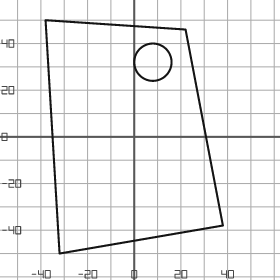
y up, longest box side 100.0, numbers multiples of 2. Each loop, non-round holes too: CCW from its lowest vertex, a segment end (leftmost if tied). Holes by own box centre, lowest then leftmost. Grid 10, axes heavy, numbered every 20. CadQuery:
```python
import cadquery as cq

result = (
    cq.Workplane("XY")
    .moveTo(-32.0, -50.0)
    .lineTo(38.0, -38.0)
    .lineTo(22.0, 46.0)
    .lineTo(-38.0, 50.0)
    .close()
    .moveTo(8.0, 32.0)
    .circle(8.0)
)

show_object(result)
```